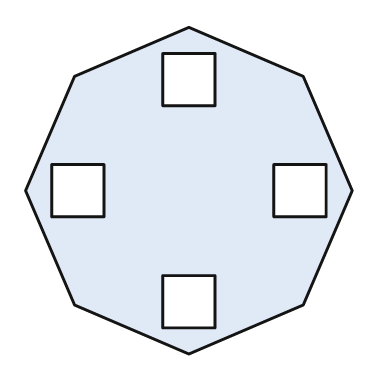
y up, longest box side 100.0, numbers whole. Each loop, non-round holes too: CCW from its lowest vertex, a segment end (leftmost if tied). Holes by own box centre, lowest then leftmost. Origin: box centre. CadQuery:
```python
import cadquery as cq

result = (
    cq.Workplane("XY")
    .moveTo(0.0, -50.0)
    .lineTo(35.0, -35.0)
    .lineTo(50.0, 0.0)
    .lineTo(35.0, 35.0)
    .lineTo(0.0, 50.0)
    .lineTo(-35.0, 35.0)
    .lineTo(-50.0, 0.0)
    .lineTo(-35.0, -35.0)
    .close()
    .moveTo(-8.0, -42.0)
    .lineTo(8.0, -42.0)
    .lineTo(8.0, -26.0)
    .lineTo(-8.0, -26.0)
    .close()
    .moveTo(-42.0, -8.0)
    .lineTo(-26.0, -8.0)
    .lineTo(-26.0, 8.0)
    .lineTo(-42.0, 8.0)
    .close()
    .moveTo(26.0, -8.0)
    .lineTo(42.0, -8.0)
    .lineTo(42.0, 8.0)
    .lineTo(26.0, 8.0)
    .close()
    .moveTo(-8.0, 26.0)
    .lineTo(8.0, 26.0)
    .lineTo(8.0, 42.0)
    .lineTo(-8.0, 42.0)
    .close()
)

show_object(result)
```